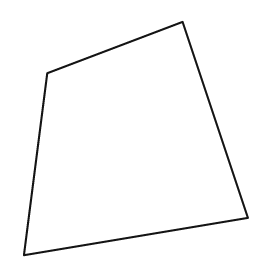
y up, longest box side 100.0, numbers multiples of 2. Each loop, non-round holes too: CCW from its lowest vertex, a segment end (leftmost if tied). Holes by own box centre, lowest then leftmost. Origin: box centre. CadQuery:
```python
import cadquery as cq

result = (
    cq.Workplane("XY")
    .moveTo(-48.0, -50.0)
    .lineTo(48.0, -34.0)
    .lineTo(20.0, 50.0)
    .lineTo(-38.0, 28.0)
    .close()
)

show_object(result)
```